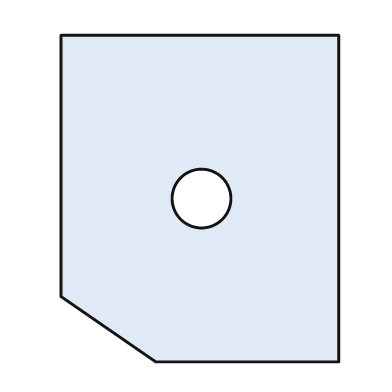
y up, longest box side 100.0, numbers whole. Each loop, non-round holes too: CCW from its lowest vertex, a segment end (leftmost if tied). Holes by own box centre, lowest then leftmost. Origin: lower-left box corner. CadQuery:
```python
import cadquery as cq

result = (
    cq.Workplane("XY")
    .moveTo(29.0, 0.0)
    .lineTo(85.0, 0.0)
    .lineTo(85.0, 100.0)
    .lineTo(0.0, 100.0)
    .lineTo(0.0, 20.0)
    .close()
    .moveTo(43.0, 50.0)
    .circle(9.0)
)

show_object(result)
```